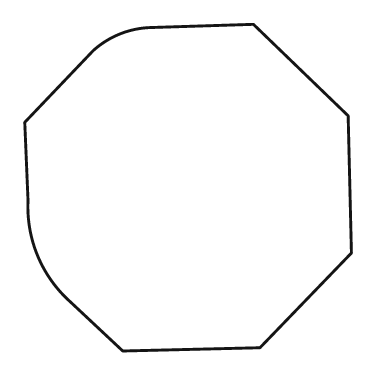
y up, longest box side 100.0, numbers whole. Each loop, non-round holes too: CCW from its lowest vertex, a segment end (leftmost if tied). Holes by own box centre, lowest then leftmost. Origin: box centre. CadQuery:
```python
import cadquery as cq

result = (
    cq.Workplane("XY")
    .moveTo(-20.0, -50.0)
    .lineTo(22.0, -49.0)
    .lineTo(50.0, -20.0)
    .lineTo(49.0, 22.0)
    .lineTo(20.0, 50.0)
    .lineTo(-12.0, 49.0)
    .threePointArc((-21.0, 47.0), (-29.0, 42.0))
    .lineTo(-50.0, 20.0)
    .lineTo(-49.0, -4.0)
    .threePointArc((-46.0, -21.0), (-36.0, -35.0))
    .close()
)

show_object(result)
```